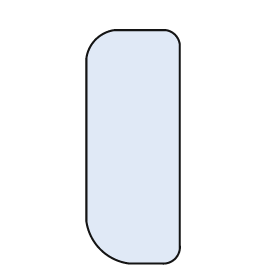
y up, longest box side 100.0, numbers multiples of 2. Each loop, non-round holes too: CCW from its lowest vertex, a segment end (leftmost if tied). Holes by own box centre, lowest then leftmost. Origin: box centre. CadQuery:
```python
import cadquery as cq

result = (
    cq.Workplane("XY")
    .moveTo(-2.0, -50.0)
    .lineTo(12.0, -50.0)
    .threePointArc((18.0, -48.0), (20.0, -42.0))
    .lineTo(20.0, 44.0)
    .threePointArc((18.0, 48.0), (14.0, 50.0))
    .lineTo(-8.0, 50.0)
    .threePointArc((-16.0, 46.0), (-20.0, 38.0))
    .lineTo(-20.0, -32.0)
    .threePointArc((-14.0, -44.0), (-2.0, -50.0))
    .close()
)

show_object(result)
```